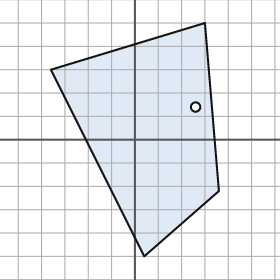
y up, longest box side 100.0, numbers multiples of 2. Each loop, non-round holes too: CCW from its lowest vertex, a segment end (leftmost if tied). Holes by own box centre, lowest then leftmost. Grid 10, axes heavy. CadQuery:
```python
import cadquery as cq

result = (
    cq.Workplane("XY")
    .moveTo(4.0, -50.0)
    .lineTo(36.0, -22.0)
    .lineTo(30.0, 50.0)
    .lineTo(-36.0, 30.0)
    .close()
    .moveTo(26.0, 14.0)
    .circle(2.0)
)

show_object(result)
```